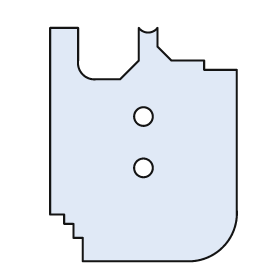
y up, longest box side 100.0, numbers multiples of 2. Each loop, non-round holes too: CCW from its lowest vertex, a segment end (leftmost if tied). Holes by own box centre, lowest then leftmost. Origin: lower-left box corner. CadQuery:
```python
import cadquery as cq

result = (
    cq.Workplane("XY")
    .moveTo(14.0, 0.0)
    .lineTo(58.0, 0.0)
    .threePointArc((74.0, 6.0), (80.0, 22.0))
    .lineTo(80.0, 82.0)
    .lineTo(66.0, 82.0)
    .lineTo(66.0, 86.0)
    .lineTo(52.0, 86.0)
    .lineTo(46.0, 92.0)
    .lineTo(46.0, 100.0)
    .threePointArc((42.0, 98.0), (38.0, 100.0))
    .lineTo(38.0, 86.0)
    .lineTo(30.0, 78.0)
    .lineTo(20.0, 78.0)
    .threePointArc((14.0, 80.0), (12.0, 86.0))
    .lineTo(12.0, 100.0)
    .lineTo(0.0, 100.0)
    .lineTo(0.0, 20.0)
    .lineTo(6.0, 20.0)
    .lineTo(6.0, 16.0)
    .lineTo(10.0, 16.0)
    .lineTo(10.0, 10.0)
    .lineTo(14.0, 10.0)
    .close()
    .moveTo(40.0, 40.0)
    .circle(4.0)
    .moveTo(40.0, 62.0)
    .circle(4.0)
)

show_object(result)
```